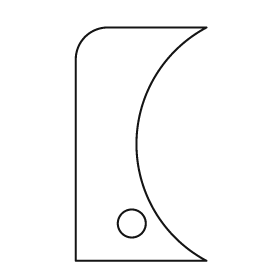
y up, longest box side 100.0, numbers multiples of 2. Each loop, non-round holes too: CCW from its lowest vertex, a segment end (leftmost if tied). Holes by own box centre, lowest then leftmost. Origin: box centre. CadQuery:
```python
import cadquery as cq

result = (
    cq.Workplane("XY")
    .moveTo(-28.0, -50.0)
    .lineTo(28.0, -50.0)
    .threePointArc((-2.0, 0.0), (28.0, 50.0))
    .lineTo(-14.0, 50.0)
    .threePointArc((-24.0, 46.0), (-28.0, 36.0))
    .close()
    .moveTo(-4.0, -34.0)
    .circle(6.0)
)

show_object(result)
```